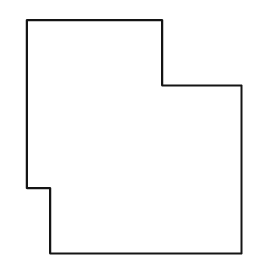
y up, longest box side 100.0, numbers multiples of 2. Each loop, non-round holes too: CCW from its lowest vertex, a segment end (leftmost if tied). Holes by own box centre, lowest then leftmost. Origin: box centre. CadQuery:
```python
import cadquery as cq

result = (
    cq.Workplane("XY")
    .moveTo(-36.0, -50.0)
    .lineTo(46.0, -50.0)
    .lineTo(46.0, 22.0)
    .lineTo(12.0, 22.0)
    .lineTo(12.0, 50.0)
    .lineTo(-46.0, 50.0)
    .lineTo(-46.0, -22.0)
    .lineTo(-36.0, -22.0)
    .close()
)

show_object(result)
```